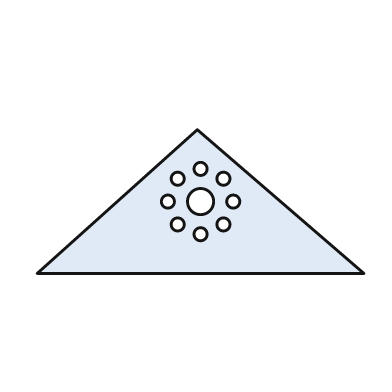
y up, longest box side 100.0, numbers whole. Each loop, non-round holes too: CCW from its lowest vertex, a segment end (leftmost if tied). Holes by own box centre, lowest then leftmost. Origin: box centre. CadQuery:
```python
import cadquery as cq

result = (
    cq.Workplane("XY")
    .moveTo(-50.0, -22.0)
    .lineTo(50.0, -22.0)
    .lineTo(-1.0, 22.0)
    .close()
    .moveTo(0.0, -10.0)
    .circle(2.0)
    .moveTo(-7.0, -7.0)
    .circle(2.0)
    .moveTo(7.0, -7.0)
    .circle(2.0)
    .moveTo(-10.0, 0.0)
    .circle(2.0)
    .moveTo(0.0, 0.0)
    .circle(4.0)
    .moveTo(10.0, 0.0)
    .circle(2.0)
    .moveTo(-7.0, 7.0)
    .circle(2.0)
    .moveTo(7.0, 7.0)
    .circle(2.0)
    .moveTo(0.0, 10.0)
    .circle(2.0)
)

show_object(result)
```